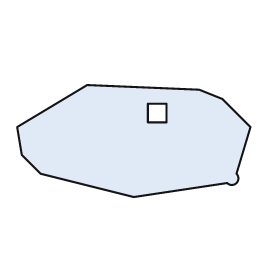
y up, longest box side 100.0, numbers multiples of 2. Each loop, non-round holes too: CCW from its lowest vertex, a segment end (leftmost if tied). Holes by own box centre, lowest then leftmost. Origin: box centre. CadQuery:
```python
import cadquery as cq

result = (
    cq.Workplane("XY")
    .moveTo(0.0, -24.0)
    .lineTo(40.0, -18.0)
    .threePointArc((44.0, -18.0), (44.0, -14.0))
    .lineTo(50.0, 6.0)
    .lineTo(38.0, 18.0)
    .lineTo(28.0, 22.0)
    .lineTo(-20.0, 24.0)
    .lineTo(-50.0, 6.0)
    .lineTo(-48.0, -6.0)
    .lineTo(-40.0, -14.0)
    .close()
    .moveTo(6.0, 8.0)
    .lineTo(14.0, 8.0)
    .lineTo(14.0, 16.0)
    .lineTo(6.0, 16.0)
    .close()
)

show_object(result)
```